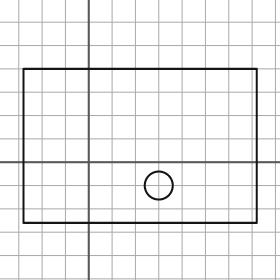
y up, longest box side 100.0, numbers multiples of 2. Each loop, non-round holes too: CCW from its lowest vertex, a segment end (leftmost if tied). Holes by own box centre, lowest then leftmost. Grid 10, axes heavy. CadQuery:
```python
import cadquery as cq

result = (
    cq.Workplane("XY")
    .moveTo(-28.0, -26.0)
    .lineTo(72.0, -26.0)
    .lineTo(72.0, 40.0)
    .lineTo(-28.0, 40.0)
    .close()
    .moveTo(30.0, -10.0)
    .circle(6.0)
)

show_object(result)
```